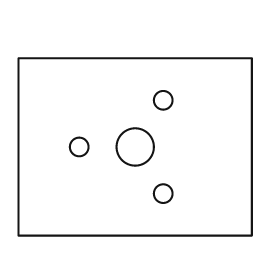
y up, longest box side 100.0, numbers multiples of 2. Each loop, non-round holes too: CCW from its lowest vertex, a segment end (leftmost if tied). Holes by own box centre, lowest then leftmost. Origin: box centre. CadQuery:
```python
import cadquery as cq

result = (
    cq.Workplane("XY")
    .moveTo(-50.0, -38.0)
    .lineTo(50.0, -38.0)
    .lineTo(50.0, 38.0)
    .lineTo(-50.0, 38.0)
    .close()
    .moveTo(12.0, -20.0)
    .circle(4.0)
    .moveTo(-24.0, 0.0)
    .circle(4.0)
    .moveTo(0.0, 0.0)
    .circle(8.0)
    .moveTo(12.0, 20.0)
    .circle(4.0)
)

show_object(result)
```